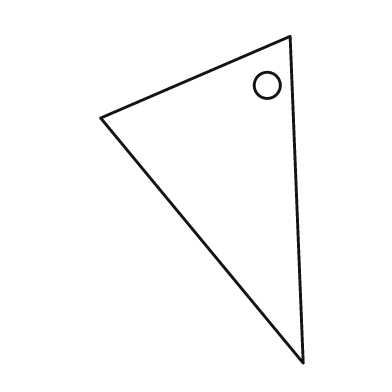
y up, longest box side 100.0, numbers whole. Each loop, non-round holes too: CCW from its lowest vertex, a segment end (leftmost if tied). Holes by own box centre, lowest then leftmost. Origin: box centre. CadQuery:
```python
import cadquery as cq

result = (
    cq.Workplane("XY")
    .moveTo(31.0, -50.0)
    .lineTo(27.0, 50.0)
    .lineTo(-31.0, 25.0)
    .close()
    .moveTo(20.0, 35.0)
    .circle(4.0)
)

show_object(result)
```